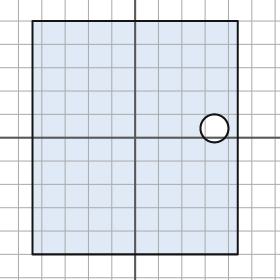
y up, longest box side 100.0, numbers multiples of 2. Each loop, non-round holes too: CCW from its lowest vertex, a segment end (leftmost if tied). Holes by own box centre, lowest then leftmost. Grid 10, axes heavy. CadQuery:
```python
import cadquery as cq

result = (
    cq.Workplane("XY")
    .moveTo(-44.0, -50.0)
    .lineTo(44.0, -50.0)
    .lineTo(44.0, 50.0)
    .lineTo(-44.0, 50.0)
    .close()
    .moveTo(34.0, 4.0)
    .circle(6.0)
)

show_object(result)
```